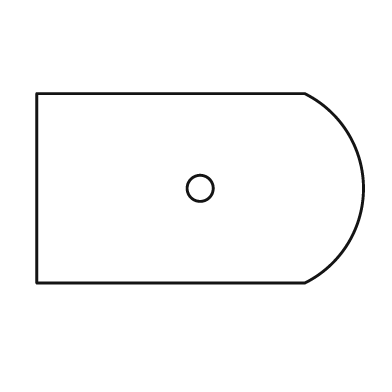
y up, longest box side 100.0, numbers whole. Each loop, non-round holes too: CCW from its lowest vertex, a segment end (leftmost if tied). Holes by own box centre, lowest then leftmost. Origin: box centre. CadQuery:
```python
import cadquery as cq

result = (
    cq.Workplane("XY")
    .moveTo(-50.0, -29.0)
    .lineTo(32.0, -29.0)
    .threePointArc((50.0, 0.0), (32.0, 29.0))
    .lineTo(-50.0, 29.0)
    .close()
    .moveTo(0.0, 0.0)
    .circle(4.0)
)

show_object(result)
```